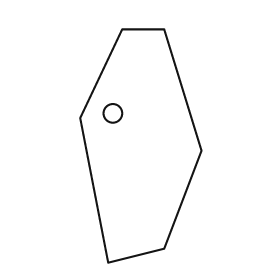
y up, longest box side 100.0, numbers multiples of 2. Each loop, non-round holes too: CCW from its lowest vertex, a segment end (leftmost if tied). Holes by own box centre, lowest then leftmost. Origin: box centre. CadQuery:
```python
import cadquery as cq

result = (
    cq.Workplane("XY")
    .moveTo(-14.0, -50.0)
    .lineTo(10.0, -44.0)
    .lineTo(26.0, -2.0)
    .lineTo(10.0, 50.0)
    .lineTo(-8.0, 50.0)
    .lineTo(-26.0, 12.0)
    .close()
    .moveTo(-12.0, 14.0)
    .circle(4.0)
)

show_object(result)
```